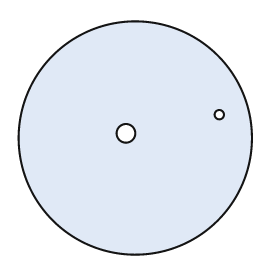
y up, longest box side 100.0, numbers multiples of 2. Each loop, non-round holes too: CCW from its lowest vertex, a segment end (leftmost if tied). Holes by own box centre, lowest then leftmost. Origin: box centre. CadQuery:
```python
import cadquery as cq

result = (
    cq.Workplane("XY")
    .moveTo(0.0, 0.0)
    .circle(50.0)
    .moveTo(-4.0, 2.0)
    .circle(4.0)
    .moveTo(36.0, 10.0)
    .circle(2.0)
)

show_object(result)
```